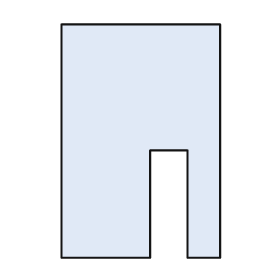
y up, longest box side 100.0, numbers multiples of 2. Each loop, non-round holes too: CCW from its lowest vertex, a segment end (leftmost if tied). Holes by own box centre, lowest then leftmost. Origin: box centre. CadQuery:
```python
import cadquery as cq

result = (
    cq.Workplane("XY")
    .moveTo(-34.0, -50.0)
    .lineTo(4.0, -50.0)
    .lineTo(4.0, -4.0)
    .lineTo(20.0, -4.0)
    .lineTo(20.0, -50.0)
    .lineTo(34.0, -50.0)
    .lineTo(34.0, 50.0)
    .lineTo(-34.0, 50.0)
    .close()
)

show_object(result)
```